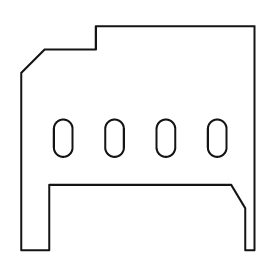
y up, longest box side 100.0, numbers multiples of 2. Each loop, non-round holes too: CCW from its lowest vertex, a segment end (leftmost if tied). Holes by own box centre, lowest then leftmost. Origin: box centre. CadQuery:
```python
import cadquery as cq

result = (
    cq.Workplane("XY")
    .moveTo(-50.0, -48.0)
    .lineTo(-38.0, -48.0)
    .lineTo(-38.0, -20.0)
    .lineTo(40.0, -20.0)
    .lineTo(46.0, -30.0)
    .lineTo(46.0, -48.0)
    .lineTo(50.0, -48.0)
    .lineTo(50.0, 48.0)
    .lineTo(-18.0, 48.0)
    .lineTo(-18.0, 38.0)
    .lineTo(-40.0, 38.0)
    .lineTo(-50.0, 28.0)
    .close()
    .moveTo(-36.0, -4.0)
    .threePointArc((-32.0, -8.0), (-28.0, -4.0))
    .lineTo(-28.0, 4.0)
    .threePointArc((-32.0, 8.0), (-36.0, 4.0))
    .close()
    .moveTo(-14.0, -4.0)
    .threePointArc((-10.0, -8.0), (-6.0, -4.0))
    .lineTo(-6.0, 4.0)
    .threePointArc((-10.0, 8.0), (-14.0, 4.0))
    .close()
    .moveTo(8.0, -4.0)
    .threePointArc((12.0, -8.0), (16.0, -4.0))
    .lineTo(16.0, 4.0)
    .threePointArc((12.0, 8.0), (8.0, 4.0))
    .close()
    .moveTo(30.0, -4.0)
    .threePointArc((34.0, -8.0), (38.0, -4.0))
    .lineTo(38.0, 4.0)
    .threePointArc((34.0, 8.0), (30.0, 4.0))
    .close()
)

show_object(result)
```